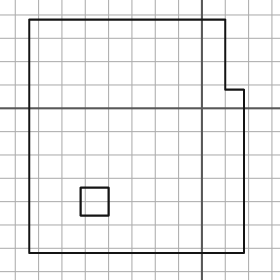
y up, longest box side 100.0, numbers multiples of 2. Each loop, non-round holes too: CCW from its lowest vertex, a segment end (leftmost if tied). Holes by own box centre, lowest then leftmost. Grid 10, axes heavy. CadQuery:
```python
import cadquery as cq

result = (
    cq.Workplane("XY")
    .moveTo(-74.0, -62.0)
    .lineTo(18.0, -62.0)
    .lineTo(18.0, 8.0)
    .lineTo(10.0, 8.0)
    .lineTo(10.0, 38.0)
    .lineTo(-74.0, 38.0)
    .close()
    .moveTo(-52.0, -46.0)
    .lineTo(-40.0, -46.0)
    .lineTo(-40.0, -34.0)
    .lineTo(-52.0, -34.0)
    .close()
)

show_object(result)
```